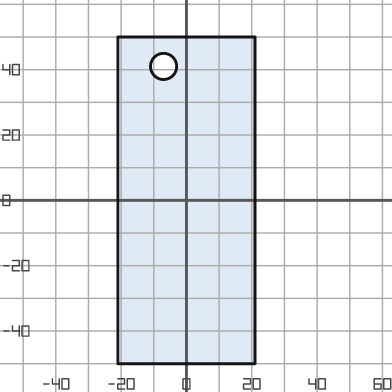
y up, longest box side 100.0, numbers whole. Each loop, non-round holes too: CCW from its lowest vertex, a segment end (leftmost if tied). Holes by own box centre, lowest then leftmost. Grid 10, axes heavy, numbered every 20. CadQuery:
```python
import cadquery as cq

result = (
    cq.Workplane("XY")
    .moveTo(-21.0, -50.0)
    .lineTo(21.0, -50.0)
    .lineTo(21.0, 50.0)
    .lineTo(-21.0, 50.0)
    .close()
    .moveTo(-7.0, 41.0)
    .circle(4.0)
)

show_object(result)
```